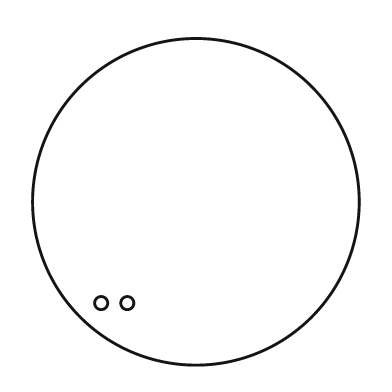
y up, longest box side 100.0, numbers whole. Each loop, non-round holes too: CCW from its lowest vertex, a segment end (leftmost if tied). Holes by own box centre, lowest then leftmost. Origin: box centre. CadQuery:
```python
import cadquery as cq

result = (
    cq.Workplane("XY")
    .moveTo(0.0, 0.0)
    .circle(50.0)
    .moveTo(-29.0, -31.0)
    .circle(2.0)
    .moveTo(-21.0, -31.0)
    .circle(2.0)
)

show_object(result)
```